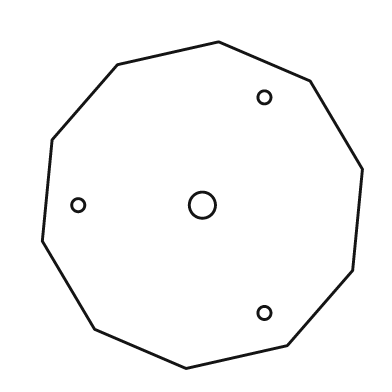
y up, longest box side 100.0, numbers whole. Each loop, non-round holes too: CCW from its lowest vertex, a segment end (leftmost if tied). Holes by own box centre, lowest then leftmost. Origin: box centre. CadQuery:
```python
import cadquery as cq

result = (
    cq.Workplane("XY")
    .moveTo(-5.0, -50.0)
    .lineTo(26.0, -43.0)
    .lineTo(46.0, -20.0)
    .lineTo(49.0, 11.0)
    .lineTo(33.0, 38.0)
    .lineTo(5.0, 50.0)
    .lineTo(-26.0, 43.0)
    .lineTo(-46.0, 20.0)
    .lineTo(-49.0, -11.0)
    .lineTo(-33.0, -38.0)
    .close()
    .moveTo(19.0, -33.0)
    .circle(2.0)
    .moveTo(-38.0, 0.0)
    .circle(2.0)
    .moveTo(0.0, 0.0)
    .circle(4.0)
    .moveTo(19.0, 33.0)
    .circle(2.0)
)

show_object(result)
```